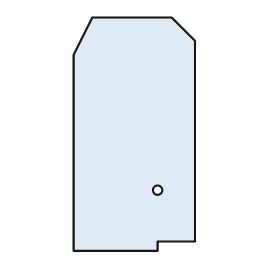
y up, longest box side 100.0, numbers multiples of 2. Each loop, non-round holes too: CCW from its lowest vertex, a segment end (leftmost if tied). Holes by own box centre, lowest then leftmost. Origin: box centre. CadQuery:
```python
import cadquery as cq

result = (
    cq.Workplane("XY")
    .moveTo(-26.0, -50.0)
    .lineTo(10.0, -50.0)
    .lineTo(10.0, -46.0)
    .lineTo(26.0, -46.0)
    .lineTo(26.0, 40.0)
    .lineTo(16.0, 50.0)
    .lineTo(-18.0, 50.0)
    .lineTo(-26.0, 34.0)
    .close()
    .moveTo(10.0, -24.0)
    .circle(2.0)
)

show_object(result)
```